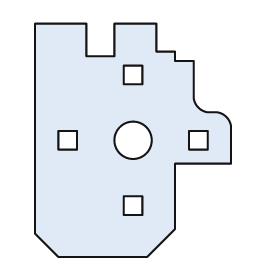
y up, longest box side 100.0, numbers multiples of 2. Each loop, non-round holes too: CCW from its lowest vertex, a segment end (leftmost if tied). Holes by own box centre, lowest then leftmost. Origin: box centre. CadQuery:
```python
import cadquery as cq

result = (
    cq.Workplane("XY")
    .moveTo(-32.0, -50.0)
    .lineTo(6.0, -50.0)
    .lineTo(18.0, -38.0)
    .lineTo(18.0, -10.0)
    .lineTo(42.0, -10.0)
    .lineTo(42.0, 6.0)
    .threePointArc((40.0, 10.0), (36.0, 12.0))
    .lineTo(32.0, 12.0)
    .threePointArc((28.0, 14.0), (26.0, 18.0))
    .lineTo(26.0, 34.0)
    .lineTo(18.0, 34.0)
    .lineTo(18.0, 38.0)
    .lineTo(10.0, 38.0)
    .lineTo(10.0, 50.0)
    .lineTo(-8.0, 50.0)
    .lineTo(-8.0, 36.0)
    .lineTo(-20.0, 36.0)
    .lineTo(-20.0, 50.0)
    .lineTo(-42.0, 50.0)
    .lineTo(-42.0, -40.0)
    .close()
    .moveTo(-4.0, -32.0)
    .lineTo(4.0, -32.0)
    .lineTo(4.0, -24.0)
    .lineTo(-4.0, -24.0)
    .close()
    .moveTo(-32.0, -4.0)
    .lineTo(-24.0, -4.0)
    .lineTo(-24.0, 4.0)
    .lineTo(-32.0, 4.0)
    .close()
    .moveTo(0.0, 0.0)
    .circle(8.0)
    .moveTo(24.0, -4.0)
    .lineTo(32.0, -4.0)
    .lineTo(32.0, 4.0)
    .lineTo(24.0, 4.0)
    .close()
    .moveTo(-4.0, 24.0)
    .lineTo(4.0, 24.0)
    .lineTo(4.0, 32.0)
    .lineTo(-4.0, 32.0)
    .close()
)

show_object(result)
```